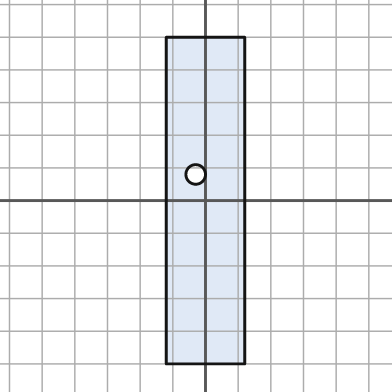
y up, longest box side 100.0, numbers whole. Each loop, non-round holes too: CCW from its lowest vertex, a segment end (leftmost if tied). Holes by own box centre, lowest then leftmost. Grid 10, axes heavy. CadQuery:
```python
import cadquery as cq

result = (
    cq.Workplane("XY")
    .moveTo(-12.0, -50.0)
    .lineTo(12.0, -50.0)
    .lineTo(12.0, 50.0)
    .lineTo(-12.0, 50.0)
    .close()
    .moveTo(-3.0, 8.0)
    .circle(3.0)
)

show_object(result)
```